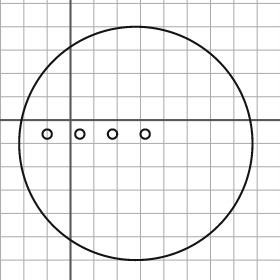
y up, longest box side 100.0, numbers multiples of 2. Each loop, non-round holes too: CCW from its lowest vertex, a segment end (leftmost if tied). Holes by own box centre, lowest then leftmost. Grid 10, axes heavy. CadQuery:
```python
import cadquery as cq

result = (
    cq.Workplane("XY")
    .moveTo(28.0, -10.0)
    .circle(50.0)
    .moveTo(-10.0, -6.0)
    .circle(2.0)
    .moveTo(4.0, -6.0)
    .circle(2.0)
    .moveTo(18.0, -6.0)
    .circle(2.0)
    .moveTo(32.0, -6.0)
    .circle(2.0)
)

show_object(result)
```